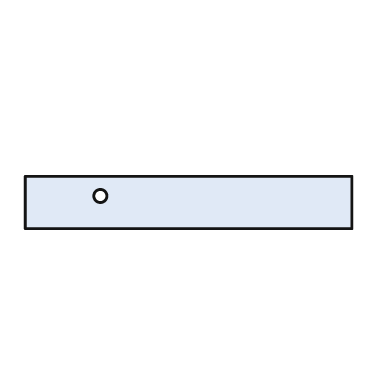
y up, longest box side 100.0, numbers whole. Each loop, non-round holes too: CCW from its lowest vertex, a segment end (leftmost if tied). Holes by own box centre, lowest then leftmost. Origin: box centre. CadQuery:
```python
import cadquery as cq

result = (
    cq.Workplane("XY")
    .moveTo(-50.0, -8.0)
    .lineTo(50.0, -8.0)
    .lineTo(50.0, 8.0)
    .lineTo(-50.0, 8.0)
    .close()
    .moveTo(-27.0, 2.0)
    .circle(2.0)
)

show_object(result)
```